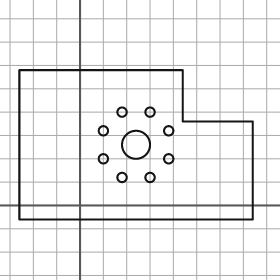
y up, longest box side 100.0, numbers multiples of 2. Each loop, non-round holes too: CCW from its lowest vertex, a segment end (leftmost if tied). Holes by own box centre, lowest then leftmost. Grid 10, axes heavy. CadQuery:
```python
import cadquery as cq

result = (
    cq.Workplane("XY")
    .moveTo(-26.0, -6.0)
    .lineTo(74.0, -6.0)
    .lineTo(74.0, 36.0)
    .lineTo(44.0, 36.0)
    .lineTo(44.0, 58.0)
    .lineTo(-26.0, 58.0)
    .close()
    .moveTo(18.0, 12.0)
    .circle(2.0)
    .moveTo(30.0, 12.0)
    .circle(2.0)
    .moveTo(10.0, 20.0)
    .circle(2.0)
    .moveTo(38.0, 20.0)
    .circle(2.0)
    .moveTo(24.0, 26.0)
    .circle(6.0)
    .moveTo(10.0, 32.0)
    .circle(2.0)
    .moveTo(38.0, 32.0)
    .circle(2.0)
    .moveTo(18.0, 40.0)
    .circle(2.0)
    .moveTo(30.0, 40.0)
    .circle(2.0)
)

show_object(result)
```